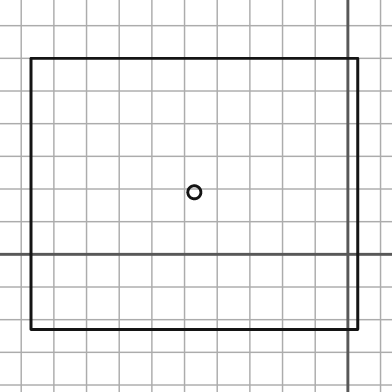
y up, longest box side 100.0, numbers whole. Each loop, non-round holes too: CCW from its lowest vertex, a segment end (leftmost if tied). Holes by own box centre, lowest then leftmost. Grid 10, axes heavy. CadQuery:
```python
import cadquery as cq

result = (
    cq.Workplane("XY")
    .moveTo(-97.0, -23.0)
    .lineTo(3.0, -23.0)
    .lineTo(3.0, 60.0)
    .lineTo(-97.0, 60.0)
    .close()
    .moveTo(-47.0, 19.0)
    .circle(2.0)
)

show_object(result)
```